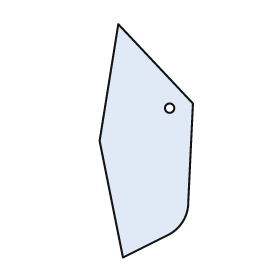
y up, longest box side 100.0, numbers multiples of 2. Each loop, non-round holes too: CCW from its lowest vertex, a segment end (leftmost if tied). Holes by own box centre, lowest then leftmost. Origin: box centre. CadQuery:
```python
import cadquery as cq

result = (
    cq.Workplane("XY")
    .moveTo(-10.0, -50.0)
    .lineTo(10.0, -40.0)
    .threePointArc((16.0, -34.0), (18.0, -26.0))
    .lineTo(20.0, 16.0)
    .lineTo(-12.0, 50.0)
    .lineTo(-20.0, 0.0)
    .close()
    .moveTo(10.0, 14.0)
    .circle(2.0)
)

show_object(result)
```